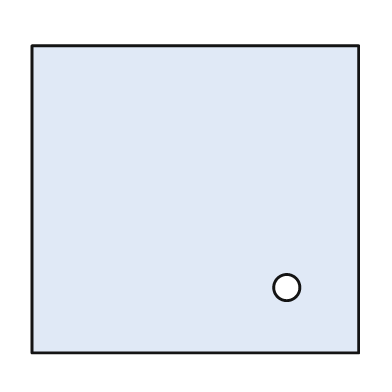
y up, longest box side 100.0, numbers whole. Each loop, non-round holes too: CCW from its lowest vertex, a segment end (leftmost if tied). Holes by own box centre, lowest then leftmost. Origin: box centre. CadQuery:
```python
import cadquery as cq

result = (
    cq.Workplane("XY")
    .moveTo(-50.0, -47.0)
    .lineTo(50.0, -47.0)
    .lineTo(50.0, 47.0)
    .lineTo(-50.0, 47.0)
    .close()
    .moveTo(28.0, -27.0)
    .circle(4.0)
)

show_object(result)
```